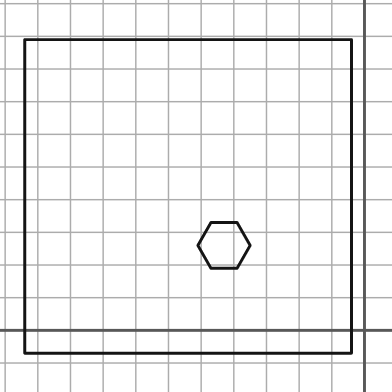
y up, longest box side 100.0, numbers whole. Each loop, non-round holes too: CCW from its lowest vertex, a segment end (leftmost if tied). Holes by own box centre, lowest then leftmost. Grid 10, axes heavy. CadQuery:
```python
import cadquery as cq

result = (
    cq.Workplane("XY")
    .moveTo(-104.0, -7.0)
    .lineTo(-4.0, -7.0)
    .lineTo(-4.0, 89.0)
    .lineTo(-104.0, 89.0)
    .close()
    .moveTo(-47.0, 19.0)
    .lineTo(-39.0, 19.0)
    .lineTo(-35.0, 26.0)
    .lineTo(-39.0, 33.0)
    .lineTo(-47.0, 33.0)
    .lineTo(-51.0, 26.0)
    .close()
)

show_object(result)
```